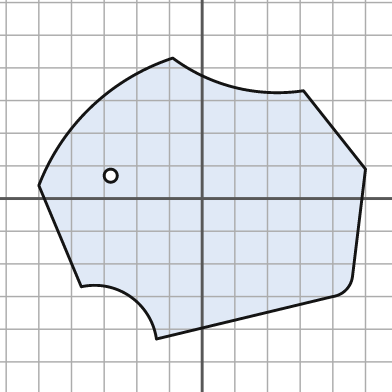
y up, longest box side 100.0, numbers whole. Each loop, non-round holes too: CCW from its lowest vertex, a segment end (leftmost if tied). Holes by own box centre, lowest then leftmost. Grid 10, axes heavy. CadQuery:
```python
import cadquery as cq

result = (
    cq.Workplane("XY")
    .moveTo(-14.0, -43.0)
    .lineTo(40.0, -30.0)
    .threePointArc((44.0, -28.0), (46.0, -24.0))
    .lineTo(50.0, 9.0)
    .lineTo(31.0, 33.0)
    .threePointArc((10.0, 34.0), (-9.0, 43.0))
    .threePointArc((-34.0, 28.0), (-50.0, 4.0))
    .lineTo(-37.0, -27.0)
    .threePointArc((-22.0, -30.0), (-14.0, -43.0))
    .close()
    .moveTo(-28.0, 7.0)
    .circle(2.0)
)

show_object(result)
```